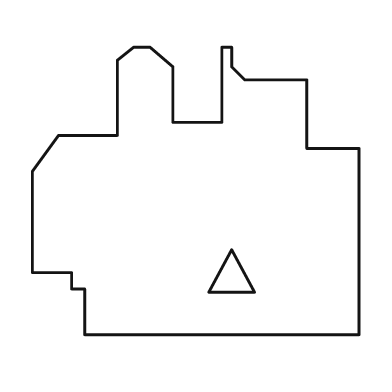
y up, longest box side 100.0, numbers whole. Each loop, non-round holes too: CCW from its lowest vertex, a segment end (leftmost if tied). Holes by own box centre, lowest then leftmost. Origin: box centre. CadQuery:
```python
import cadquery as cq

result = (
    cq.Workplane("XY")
    .moveTo(-34.0, -44.0)
    .lineTo(50.0, -44.0)
    .lineTo(50.0, 13.0)
    .lineTo(34.0, 13.0)
    .lineTo(34.0, 34.0)
    .lineTo(15.0, 34.0)
    .lineTo(11.0, 38.0)
    .lineTo(11.0, 44.0)
    .lineTo(8.0, 44.0)
    .lineTo(8.0, 21.0)
    .lineTo(-7.0, 21.0)
    .lineTo(-7.0, 38.0)
    .lineTo(-14.0, 44.0)
    .lineTo(-19.0, 44.0)
    .lineTo(-24.0, 40.0)
    .lineTo(-24.0, 17.0)
    .lineTo(-42.0, 17.0)
    .lineTo(-50.0, 6.0)
    .lineTo(-50.0, -25.0)
    .lineTo(-38.0, -25.0)
    .lineTo(-38.0, -30.0)
    .lineTo(-34.0, -30.0)
    .close()
    .moveTo(4.0, -31.0)
    .lineTo(18.0, -31.0)
    .lineTo(11.0, -18.0)
    .close()
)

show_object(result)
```